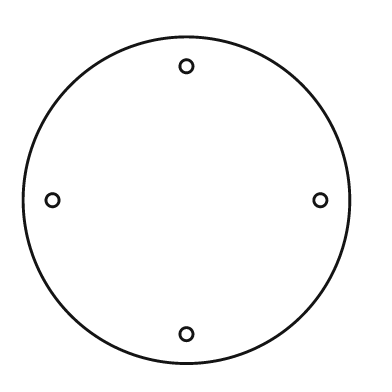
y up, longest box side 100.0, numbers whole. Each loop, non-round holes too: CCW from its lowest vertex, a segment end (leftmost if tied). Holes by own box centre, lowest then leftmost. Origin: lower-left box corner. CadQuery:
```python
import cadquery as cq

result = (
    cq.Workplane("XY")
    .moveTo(50.0, 50.0)
    .circle(50.0)
    .moveTo(50.0, 9.0)
    .circle(2.0)
    .moveTo(9.0, 50.0)
    .circle(2.0)
    .moveTo(91.0, 50.0)
    .circle(2.0)
    .moveTo(50.0, 91.0)
    .circle(2.0)
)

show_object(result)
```